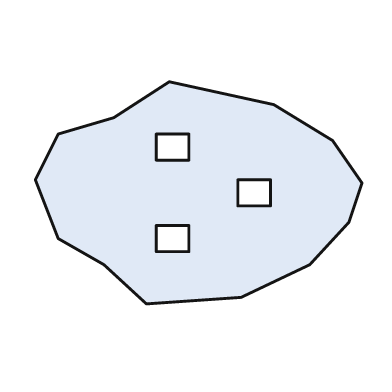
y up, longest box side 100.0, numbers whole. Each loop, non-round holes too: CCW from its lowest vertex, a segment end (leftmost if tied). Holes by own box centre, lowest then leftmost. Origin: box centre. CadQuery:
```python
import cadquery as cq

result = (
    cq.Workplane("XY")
    .moveTo(-16.0, -34.0)
    .lineTo(13.0, -32.0)
    .lineTo(34.0, -22.0)
    .lineTo(46.0, -9.0)
    .lineTo(50.0, 3.0)
    .lineTo(41.0, 16.0)
    .lineTo(23.0, 27.0)
    .lineTo(-9.0, 34.0)
    .lineTo(-26.0, 23.0)
    .lineTo(-43.0, 18.0)
    .lineTo(-50.0, 4.0)
    .lineTo(-43.0, -14.0)
    .lineTo(-29.0, -22.0)
    .close()
    .moveTo(-13.0, -18.0)
    .lineTo(-3.0, -18.0)
    .lineTo(-3.0, -10.0)
    .lineTo(-13.0, -10.0)
    .close()
    .moveTo(12.0, -4.0)
    .lineTo(22.0, -4.0)
    .lineTo(22.0, 4.0)
    .lineTo(12.0, 4.0)
    .close()
    .moveTo(-13.0, 10.0)
    .lineTo(-3.0, 10.0)
    .lineTo(-3.0, 18.0)
    .lineTo(-13.0, 18.0)
    .close()
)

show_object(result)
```